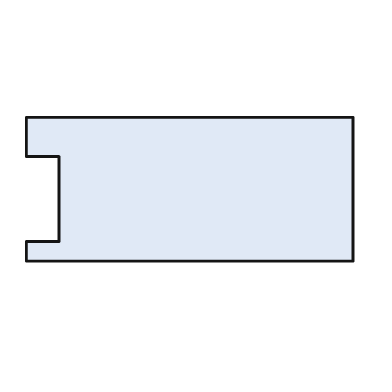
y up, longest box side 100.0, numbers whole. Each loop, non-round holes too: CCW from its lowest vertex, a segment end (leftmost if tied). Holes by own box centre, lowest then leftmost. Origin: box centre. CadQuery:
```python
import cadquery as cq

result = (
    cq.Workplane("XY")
    .moveTo(-50.0, -22.0)
    .lineTo(50.0, -22.0)
    .lineTo(50.0, 22.0)
    .lineTo(-50.0, 22.0)
    .lineTo(-50.0, 10.0)
    .lineTo(-40.0, 10.0)
    .lineTo(-40.0, -16.0)
    .lineTo(-50.0, -16.0)
    .close()
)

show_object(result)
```